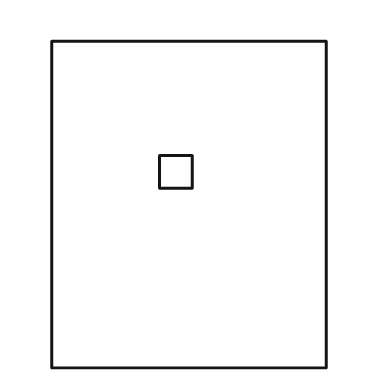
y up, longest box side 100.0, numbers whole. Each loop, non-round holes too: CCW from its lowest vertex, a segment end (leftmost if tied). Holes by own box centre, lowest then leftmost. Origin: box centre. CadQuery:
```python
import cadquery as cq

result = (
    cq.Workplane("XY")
    .moveTo(-42.0, -50.0)
    .lineTo(42.0, -50.0)
    .lineTo(42.0, 50.0)
    .lineTo(-42.0, 50.0)
    .close()
    .moveTo(-9.0, 5.0)
    .lineTo(1.0, 5.0)
    .lineTo(1.0, 15.0)
    .lineTo(-9.0, 15.0)
    .close()
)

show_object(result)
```